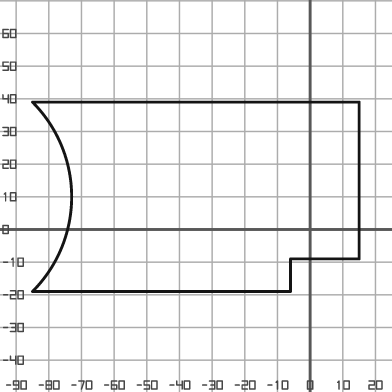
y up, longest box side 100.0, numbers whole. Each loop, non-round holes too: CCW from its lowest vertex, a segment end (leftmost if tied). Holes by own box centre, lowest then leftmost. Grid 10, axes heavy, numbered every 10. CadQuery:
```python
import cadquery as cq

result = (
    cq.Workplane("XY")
    .moveTo(-85.0, -19.0)
    .lineTo(-6.0, -19.0)
    .lineTo(-6.0, -9.0)
    .lineTo(15.0, -9.0)
    .lineTo(15.0, 39.0)
    .lineTo(-85.0, 39.0)
    .threePointArc((-73.0, 10.0), (-85.0, -19.0))
    .close()
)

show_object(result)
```